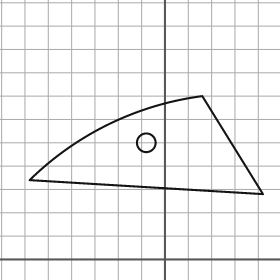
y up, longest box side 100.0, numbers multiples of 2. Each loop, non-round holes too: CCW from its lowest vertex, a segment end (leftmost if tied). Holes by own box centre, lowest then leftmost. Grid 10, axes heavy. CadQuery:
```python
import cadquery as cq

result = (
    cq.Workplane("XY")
    .moveTo(42.0, 28.0)
    .lineTo(16.0, 70.0)
    .threePointArc((-24.0, 58.0), (-58.0, 34.0))
    .close()
    .moveTo(-8.0, 50.0)
    .circle(4.0)
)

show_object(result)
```